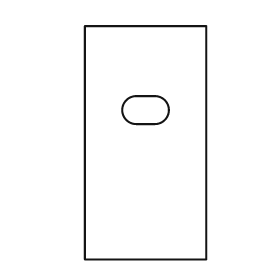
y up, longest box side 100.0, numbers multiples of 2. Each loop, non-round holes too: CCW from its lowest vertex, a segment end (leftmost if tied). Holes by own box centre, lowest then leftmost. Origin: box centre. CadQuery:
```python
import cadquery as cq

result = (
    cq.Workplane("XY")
    .moveTo(-26.0, -50.0)
    .lineTo(26.0, -50.0)
    .lineTo(26.0, 50.0)
    .lineTo(-26.0, 50.0)
    .close()
    .moveTo(-4.0, 8.0)
    .lineTo(4.0, 8.0)
    .threePointArc((10.0, 14.0), (4.0, 20.0))
    .lineTo(-4.0, 20.0)
    .threePointArc((-10.0, 14.0), (-4.0, 8.0))
    .close()
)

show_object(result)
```